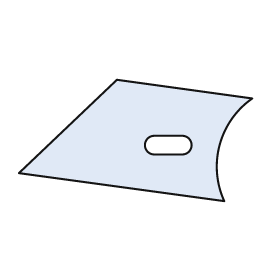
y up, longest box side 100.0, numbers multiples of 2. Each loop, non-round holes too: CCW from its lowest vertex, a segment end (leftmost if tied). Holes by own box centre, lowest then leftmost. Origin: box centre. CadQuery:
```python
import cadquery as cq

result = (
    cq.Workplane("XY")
    .moveTo(38.0, -26.0)
    .threePointArc((36.0, -2.0), (50.0, 18.0))
    .lineTo(-8.0, 26.0)
    .lineTo(-50.0, -14.0)
    .close()
    .moveTo(8.0, -6.0)
    .lineTo(20.0, -6.0)
    .threePointArc((24.0, -2.0), (20.0, 2.0))
    .lineTo(8.0, 2.0)
    .threePointArc((4.0, -2.0), (8.0, -6.0))
    .close()
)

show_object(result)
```